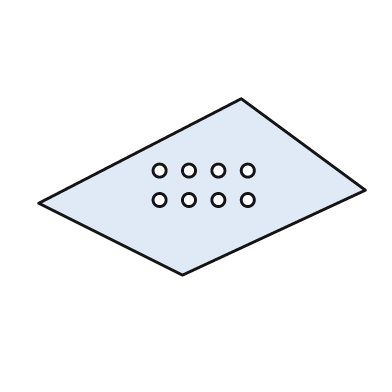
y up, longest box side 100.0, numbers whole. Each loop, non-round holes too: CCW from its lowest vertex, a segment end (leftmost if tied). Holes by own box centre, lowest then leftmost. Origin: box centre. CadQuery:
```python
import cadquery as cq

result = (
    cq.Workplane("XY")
    .moveTo(-6.0, -27.0)
    .lineTo(50.0, -1.0)
    .lineTo(12.0, 27.0)
    .lineTo(-50.0, -5.0)
    .close()
    .moveTo(-13.0, -4.0)
    .circle(2.0)
    .moveTo(-4.0, -4.0)
    .circle(2.0)
    .moveTo(5.0, -4.0)
    .circle(2.0)
    .moveTo(14.0, -4.0)
    .circle(2.0)
    .moveTo(-13.0, 5.0)
    .circle(2.0)
    .moveTo(-4.0, 5.0)
    .circle(2.0)
    .moveTo(5.0, 5.0)
    .circle(2.0)
    .moveTo(14.0, 5.0)
    .circle(2.0)
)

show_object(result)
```